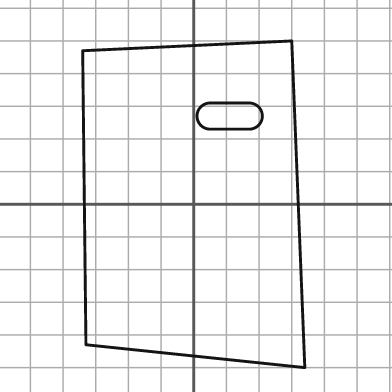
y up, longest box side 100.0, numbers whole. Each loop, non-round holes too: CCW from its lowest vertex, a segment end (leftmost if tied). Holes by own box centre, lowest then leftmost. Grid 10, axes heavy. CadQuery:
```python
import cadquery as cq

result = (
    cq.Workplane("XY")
    .moveTo(34.0, -50.0)
    .lineTo(30.0, 50.0)
    .lineTo(-34.0, 47.0)
    .lineTo(-33.0, -43.0)
    .close()
    .moveTo(5.0, 23.0)
    .lineTo(17.0, 23.0)
    .threePointArc((21.0, 27.0), (17.0, 31.0))
    .lineTo(5.0, 31.0)
    .threePointArc((1.0, 27.0), (5.0, 23.0))
    .close()
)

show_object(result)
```